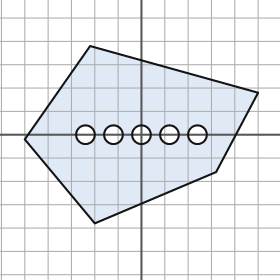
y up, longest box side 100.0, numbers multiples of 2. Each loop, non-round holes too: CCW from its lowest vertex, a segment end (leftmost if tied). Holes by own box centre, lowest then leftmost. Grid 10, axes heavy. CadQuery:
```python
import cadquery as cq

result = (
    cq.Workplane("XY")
    .moveTo(-20.0, -38.0)
    .lineTo(32.0, -16.0)
    .lineTo(50.0, 18.0)
    .lineTo(-22.0, 38.0)
    .lineTo(-50.0, -2.0)
    .close()
    .moveTo(-24.0, 0.0)
    .circle(4.0)
    .moveTo(-12.0, 0.0)
    .circle(4.0)
    .moveTo(0.0, 0.0)
    .circle(4.0)
    .moveTo(12.0, 0.0)
    .circle(4.0)
    .moveTo(24.0, 0.0)
    .circle(4.0)
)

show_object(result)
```